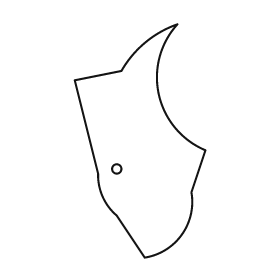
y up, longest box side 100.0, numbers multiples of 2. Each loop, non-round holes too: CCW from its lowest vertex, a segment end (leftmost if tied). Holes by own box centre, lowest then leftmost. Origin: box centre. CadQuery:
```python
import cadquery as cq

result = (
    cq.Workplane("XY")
    .moveTo(2.0, -50.0)
    .threePointArc((18.0, -40.0), (22.0, -22.0))
    .lineTo(28.0, -4.0)
    .threePointArc((8.0, 20.0), (16.0, 50.0))
    .threePointArc((2.0, 42.0), (-8.0, 30.0))
    .lineTo(-28.0, 26.0)
    .lineTo(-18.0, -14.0)
    .threePointArc((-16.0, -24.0), (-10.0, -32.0))
    .close()
    .moveTo(-10.0, -12.0)
    .circle(2.0)
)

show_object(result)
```